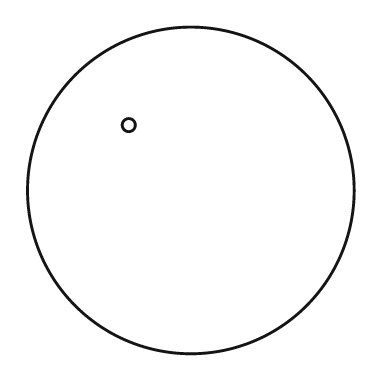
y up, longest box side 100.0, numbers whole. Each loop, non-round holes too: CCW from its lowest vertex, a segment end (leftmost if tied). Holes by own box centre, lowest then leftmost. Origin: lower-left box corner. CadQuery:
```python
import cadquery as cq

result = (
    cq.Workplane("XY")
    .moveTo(50.0, 50.0)
    .circle(50.0)
    .moveTo(31.0, 70.0)
    .circle(2.0)
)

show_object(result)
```